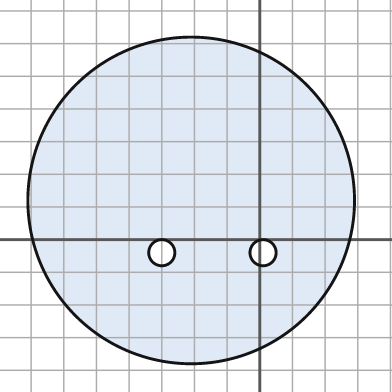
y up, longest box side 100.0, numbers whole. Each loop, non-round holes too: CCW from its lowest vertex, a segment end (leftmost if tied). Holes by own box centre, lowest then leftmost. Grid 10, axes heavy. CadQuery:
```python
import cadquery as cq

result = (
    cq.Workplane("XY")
    .moveTo(-21.0, 12.0)
    .circle(50.0)
    .moveTo(-30.0, -4.0)
    .circle(4.0)
    .moveTo(1.0, -4.0)
    .circle(4.0)
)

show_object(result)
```